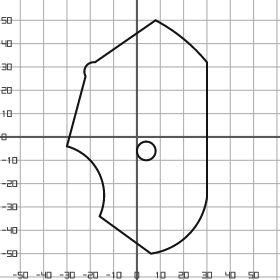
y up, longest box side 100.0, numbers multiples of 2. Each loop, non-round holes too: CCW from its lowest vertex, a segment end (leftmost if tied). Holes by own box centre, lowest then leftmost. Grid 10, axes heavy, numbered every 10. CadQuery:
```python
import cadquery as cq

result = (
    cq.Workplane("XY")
    .moveTo(6.0, -50.0)
    .threePointArc((22.0, -42.0), (30.0, -26.0))
    .lineTo(30.0, 32.0)
    .threePointArc((20.0, 42.0), (8.0, 50.0))
    .lineTo(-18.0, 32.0)
    .threePointArc((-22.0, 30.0), (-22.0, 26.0))
    .lineTo(-30.0, -4.0)
    .threePointArc((-16.0, -16.0), (-16.0, -34.0))
    .close()
    .moveTo(4.0, -6.0)
    .circle(4.0)
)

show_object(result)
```